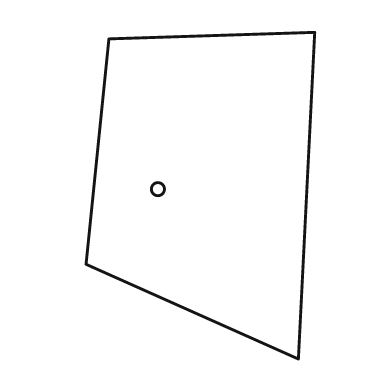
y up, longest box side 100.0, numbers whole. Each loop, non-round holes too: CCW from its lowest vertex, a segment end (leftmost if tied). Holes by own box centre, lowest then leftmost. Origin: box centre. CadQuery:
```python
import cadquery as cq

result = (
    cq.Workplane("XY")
    .moveTo(30.0, -50.0)
    .lineTo(35.0, 50.0)
    .lineTo(-28.0, 48.0)
    .lineTo(-35.0, -21.0)
    .close()
    .moveTo(-13.0, 2.0)
    .circle(2.0)
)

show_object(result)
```